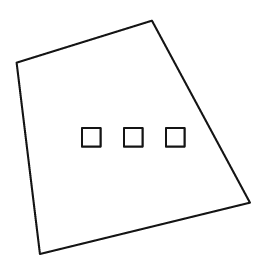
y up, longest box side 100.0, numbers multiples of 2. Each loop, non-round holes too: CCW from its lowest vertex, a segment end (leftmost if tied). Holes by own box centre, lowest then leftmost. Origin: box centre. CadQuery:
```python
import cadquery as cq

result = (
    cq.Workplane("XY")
    .moveTo(-40.0, -50.0)
    .lineTo(50.0, -28.0)
    .lineTo(8.0, 50.0)
    .lineTo(-50.0, 32.0)
    .close()
    .moveTo(-22.0, -4.0)
    .lineTo(-14.0, -4.0)
    .lineTo(-14.0, 4.0)
    .lineTo(-22.0, 4.0)
    .close()
    .moveTo(-4.0, -4.0)
    .lineTo(4.0, -4.0)
    .lineTo(4.0, 4.0)
    .lineTo(-4.0, 4.0)
    .close()
    .moveTo(14.0, -4.0)
    .lineTo(22.0, -4.0)
    .lineTo(22.0, 4.0)
    .lineTo(14.0, 4.0)
    .close()
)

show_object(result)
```